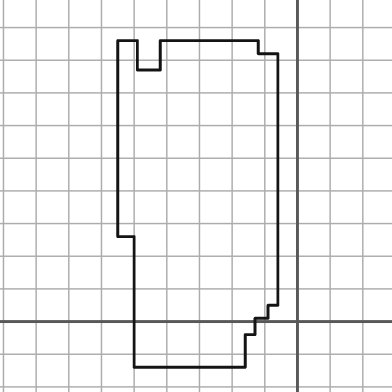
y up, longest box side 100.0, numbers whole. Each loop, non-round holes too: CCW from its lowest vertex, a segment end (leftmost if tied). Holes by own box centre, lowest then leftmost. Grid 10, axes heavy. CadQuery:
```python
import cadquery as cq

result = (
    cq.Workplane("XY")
    .moveTo(-50.0, -14.0)
    .lineTo(-16.0, -14.0)
    .lineTo(-16.0, -4.0)
    .lineTo(-13.0, -4.0)
    .lineTo(-13.0, 1.0)
    .lineTo(-9.0, 1.0)
    .lineTo(-9.0, 5.0)
    .lineTo(-6.0, 5.0)
    .lineTo(-6.0, 82.0)
    .lineTo(-12.0, 82.0)
    .lineTo(-12.0, 86.0)
    .lineTo(-42.0, 86.0)
    .lineTo(-42.0, 77.0)
    .lineTo(-49.0, 77.0)
    .lineTo(-49.0, 86.0)
    .lineTo(-55.0, 86.0)
    .lineTo(-55.0, 26.0)
    .lineTo(-50.0, 26.0)
    .close()
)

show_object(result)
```